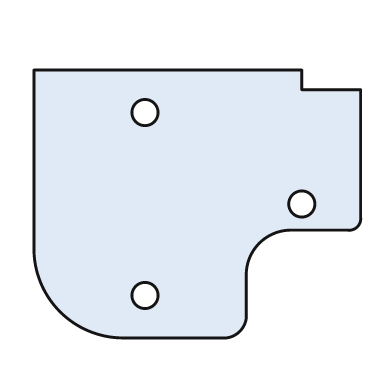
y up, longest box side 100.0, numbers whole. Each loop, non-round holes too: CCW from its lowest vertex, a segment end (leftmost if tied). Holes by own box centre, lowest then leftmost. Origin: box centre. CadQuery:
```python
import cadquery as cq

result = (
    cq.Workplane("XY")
    .moveTo(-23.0, -41.0)
    .lineTo(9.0, -41.0)
    .threePointArc((13.0, -39.0), (15.0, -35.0))
    .lineTo(15.0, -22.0)
    .threePointArc((19.0, -12.0), (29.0, -8.0))
    .lineTo(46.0, -8.0)
    .threePointArc((49.0, -7.0), (50.0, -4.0))
    .lineTo(50.0, 35.0)
    .lineTo(32.0, 35.0)
    .lineTo(32.0, 41.0)
    .lineTo(-50.0, 41.0)
    .lineTo(-50.0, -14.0)
    .threePointArc((-42.0, -33.0), (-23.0, -41.0))
    .close()
    .moveTo(-16.0, -28.0)
    .circle(4.0)
    .moveTo(32.0, 0.0)
    .circle(4.0)
    .moveTo(-16.0, 28.0)
    .circle(4.0)
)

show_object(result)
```